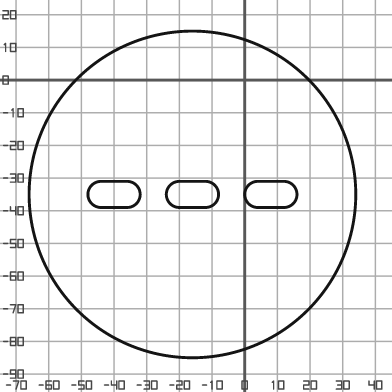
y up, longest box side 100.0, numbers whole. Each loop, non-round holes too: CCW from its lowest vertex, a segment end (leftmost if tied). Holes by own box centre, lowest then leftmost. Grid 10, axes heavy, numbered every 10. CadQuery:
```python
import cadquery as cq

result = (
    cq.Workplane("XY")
    .moveTo(-16.0, -35.0)
    .circle(50.0)
    .moveTo(-44.0, -39.0)
    .lineTo(-36.0, -39.0)
    .threePointArc((-32.0, -35.0), (-36.0, -31.0))
    .lineTo(-44.0, -31.0)
    .threePointArc((-48.0, -35.0), (-44.0, -39.0))
    .close()
    .moveTo(-20.0, -39.0)
    .lineTo(-12.0, -39.0)
    .threePointArc((-8.0, -35.0), (-12.0, -31.0))
    .lineTo(-20.0, -31.0)
    .threePointArc((-24.0, -35.0), (-20.0, -39.0))
    .close()
    .moveTo(4.0, -39.0)
    .lineTo(12.0, -39.0)
    .threePointArc((16.0, -35.0), (12.0, -31.0))
    .lineTo(4.0, -31.0)
    .threePointArc((0.0, -35.0), (4.0, -39.0))
    .close()
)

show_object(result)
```